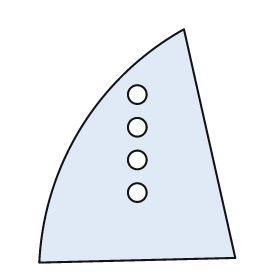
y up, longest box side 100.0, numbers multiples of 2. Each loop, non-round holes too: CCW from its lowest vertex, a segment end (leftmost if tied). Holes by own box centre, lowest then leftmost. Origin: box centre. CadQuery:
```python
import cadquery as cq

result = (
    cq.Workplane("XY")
    .moveTo(-42.0, -50.0)
    .lineTo(42.0, -48.0)
    .lineTo(20.0, 50.0)
    .threePointArc((-24.0, 8.0), (-42.0, -50.0))
    .close()
    .moveTo(0.0, -20.0)
    .circle(4.0)
    .moveTo(0.0, -6.0)
    .circle(4.0)
    .moveTo(0.0, 8.0)
    .circle(4.0)
    .moveTo(0.0, 22.0)
    .circle(4.0)
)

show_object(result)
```